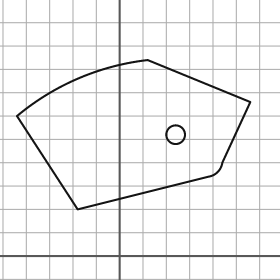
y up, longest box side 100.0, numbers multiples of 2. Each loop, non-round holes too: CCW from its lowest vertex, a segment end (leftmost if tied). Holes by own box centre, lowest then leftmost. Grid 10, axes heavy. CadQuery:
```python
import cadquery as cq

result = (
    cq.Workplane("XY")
    .moveTo(-18.0, 20.0)
    .lineTo(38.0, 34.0)
    .threePointArc((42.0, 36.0), (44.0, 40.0))
    .lineTo(56.0, 66.0)
    .lineTo(12.0, 84.0)
    .threePointArc((-18.0, 76.0), (-44.0, 60.0))
    .close()
    .moveTo(24.0, 52.0)
    .circle(4.0)
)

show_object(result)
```